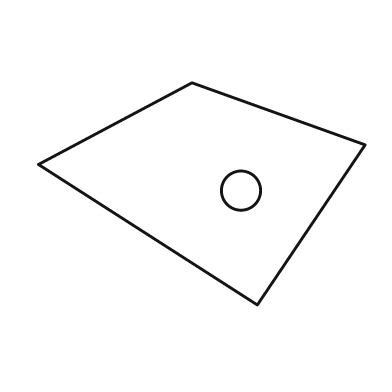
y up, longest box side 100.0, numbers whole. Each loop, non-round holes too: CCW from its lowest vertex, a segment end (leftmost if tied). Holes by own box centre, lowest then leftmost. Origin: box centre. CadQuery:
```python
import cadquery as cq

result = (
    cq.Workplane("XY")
    .moveTo(17.0, -34.0)
    .lineTo(50.0, 15.0)
    .lineTo(-3.0, 34.0)
    .lineTo(-50.0, 9.0)
    .close()
    .moveTo(12.0, 1.0)
    .circle(6.0)
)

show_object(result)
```